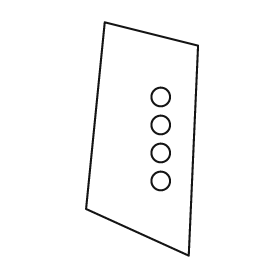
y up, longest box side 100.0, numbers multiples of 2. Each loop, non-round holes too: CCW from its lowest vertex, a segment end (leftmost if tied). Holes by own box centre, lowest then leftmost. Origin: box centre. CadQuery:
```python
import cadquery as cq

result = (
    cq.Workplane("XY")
    .moveTo(20.0, -50.0)
    .lineTo(24.0, 40.0)
    .lineTo(-16.0, 50.0)
    .lineTo(-24.0, -30.0)
    .close()
    .moveTo(8.0, -18.0)
    .circle(4.0)
    .moveTo(8.0, -6.0)
    .circle(4.0)
    .moveTo(8.0, 6.0)
    .circle(4.0)
    .moveTo(8.0, 18.0)
    .circle(4.0)
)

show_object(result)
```